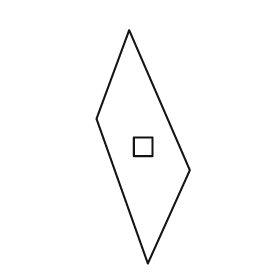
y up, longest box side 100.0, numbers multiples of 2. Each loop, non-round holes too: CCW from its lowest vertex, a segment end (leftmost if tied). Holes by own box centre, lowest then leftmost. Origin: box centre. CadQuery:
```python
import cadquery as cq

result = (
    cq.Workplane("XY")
    .moveTo(2.0, -50.0)
    .lineTo(20.0, -10.0)
    .lineTo(-6.0, 50.0)
    .lineTo(-20.0, 12.0)
    .close()
    .moveTo(-4.0, -4.0)
    .lineTo(4.0, -4.0)
    .lineTo(4.0, 4.0)
    .lineTo(-4.0, 4.0)
    .close()
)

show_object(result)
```